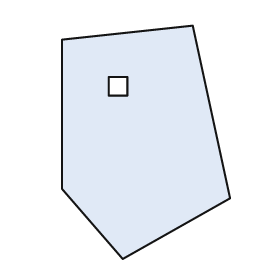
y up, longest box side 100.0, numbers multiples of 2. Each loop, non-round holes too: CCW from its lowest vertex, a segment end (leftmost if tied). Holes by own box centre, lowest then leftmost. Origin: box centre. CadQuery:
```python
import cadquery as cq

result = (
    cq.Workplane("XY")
    .moveTo(-10.0, -50.0)
    .lineTo(36.0, -24.0)
    .lineTo(20.0, 50.0)
    .lineTo(-36.0, 44.0)
    .lineTo(-36.0, -20.0)
    .close()
    .moveTo(-16.0, 20.0)
    .lineTo(-8.0, 20.0)
    .lineTo(-8.0, 28.0)
    .lineTo(-16.0, 28.0)
    .close()
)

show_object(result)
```